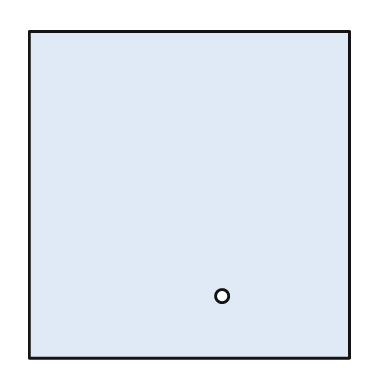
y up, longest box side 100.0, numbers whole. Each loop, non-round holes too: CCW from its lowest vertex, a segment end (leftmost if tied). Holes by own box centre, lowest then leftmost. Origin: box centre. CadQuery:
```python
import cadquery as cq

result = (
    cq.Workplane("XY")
    .moveTo(-49.0, -50.0)
    .lineTo(49.0, -50.0)
    .lineTo(49.0, 50.0)
    .lineTo(-49.0, 50.0)
    .close()
    .moveTo(10.0, -31.0)
    .circle(2.0)
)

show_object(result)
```